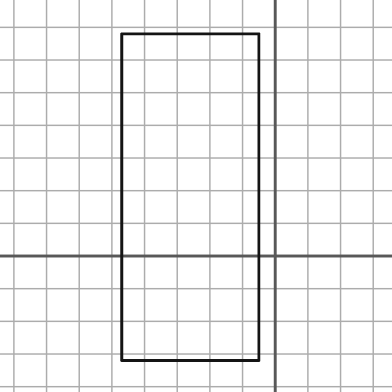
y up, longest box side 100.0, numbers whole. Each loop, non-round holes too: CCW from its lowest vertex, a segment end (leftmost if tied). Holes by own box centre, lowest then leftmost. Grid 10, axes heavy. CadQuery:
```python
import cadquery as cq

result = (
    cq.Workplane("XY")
    .moveTo(-47.0, -32.0)
    .lineTo(-5.0, -32.0)
    .lineTo(-5.0, 68.0)
    .lineTo(-47.0, 68.0)
    .close()
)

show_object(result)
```